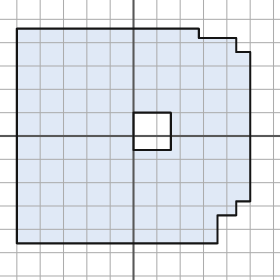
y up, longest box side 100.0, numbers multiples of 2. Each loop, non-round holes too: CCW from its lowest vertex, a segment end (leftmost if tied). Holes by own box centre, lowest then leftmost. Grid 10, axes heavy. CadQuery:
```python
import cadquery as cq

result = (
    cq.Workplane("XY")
    .moveTo(-50.0, -46.0)
    .lineTo(36.0, -46.0)
    .lineTo(36.0, -34.0)
    .lineTo(44.0, -34.0)
    .lineTo(44.0, -28.0)
    .lineTo(50.0, -28.0)
    .lineTo(50.0, 36.0)
    .lineTo(44.0, 36.0)
    .lineTo(44.0, 42.0)
    .lineTo(28.0, 42.0)
    .lineTo(28.0, 46.0)
    .lineTo(-50.0, 46.0)
    .close()
    .moveTo(0.0, -6.0)
    .lineTo(16.0, -6.0)
    .lineTo(16.0, 10.0)
    .lineTo(0.0, 10.0)
    .close()
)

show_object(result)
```